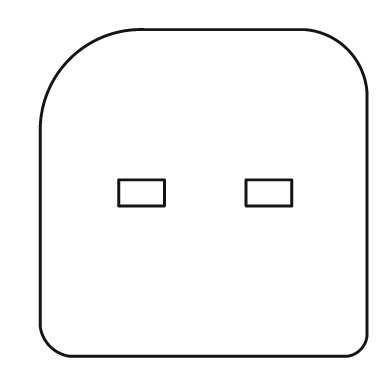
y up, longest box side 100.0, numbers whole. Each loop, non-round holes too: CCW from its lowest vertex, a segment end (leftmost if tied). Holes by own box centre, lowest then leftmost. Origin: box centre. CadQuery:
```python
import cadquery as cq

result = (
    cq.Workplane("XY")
    .moveTo(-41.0, -50.0)
    .lineTo(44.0, -50.0)
    .threePointArc((48.0, -48.0), (50.0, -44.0))
    .lineTo(50.0, 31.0)
    .threePointArc((44.0, 44.0), (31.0, 50.0))
    .lineTo(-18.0, 50.0)
    .threePointArc((-41.0, 41.0), (-50.0, 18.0))
    .lineTo(-50.0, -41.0)
    .threePointArc((-47.0, -47.0), (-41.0, -50.0))
    .close()
    .moveTo(-26.0, -4.0)
    .lineTo(-12.0, -4.0)
    .lineTo(-12.0, 4.0)
    .lineTo(-26.0, 4.0)
    .close()
    .moveTo(13.0, -4.0)
    .lineTo(27.0, -4.0)
    .lineTo(27.0, 4.0)
    .lineTo(13.0, 4.0)
    .close()
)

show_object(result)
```